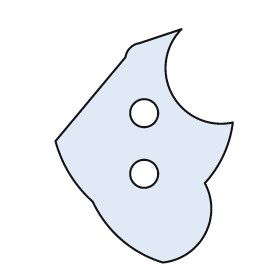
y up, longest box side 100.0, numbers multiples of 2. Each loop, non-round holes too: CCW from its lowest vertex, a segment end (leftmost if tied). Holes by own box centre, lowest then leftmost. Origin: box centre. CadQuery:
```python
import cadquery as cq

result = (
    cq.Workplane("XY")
    .moveTo(8.0, -50.0)
    .threePointArc((26.0, -38.0), (26.0, -16.0))
    .threePointArc((34.0, -4.0), (38.0, 10.0))
    .threePointArc((12.0, 22.0), (16.0, 50.0))
    .lineTo(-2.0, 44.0)
    .threePointArc((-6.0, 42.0), (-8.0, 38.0))
    .lineTo(-38.0, 2.0)
    .threePointArc((-32.0, -12.0), (-22.0, -24.0))
    .threePointArc((-10.0, -40.0), (8.0, -50.0))
    .close()
    .moveTo(0.0, -12.0)
    .circle(6.0)
    .moveTo(0.0, 14.0)
    .circle(6.0)
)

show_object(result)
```